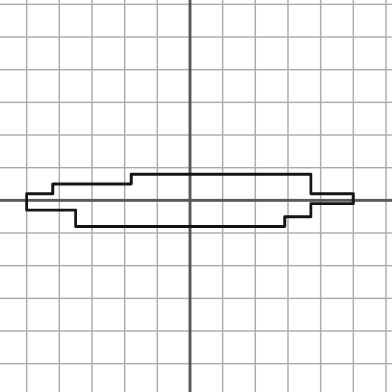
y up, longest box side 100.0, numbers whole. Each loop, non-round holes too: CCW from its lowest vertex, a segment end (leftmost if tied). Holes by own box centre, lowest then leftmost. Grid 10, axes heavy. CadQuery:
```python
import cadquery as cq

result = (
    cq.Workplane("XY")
    .moveTo(-35.0, -8.0)
    .lineTo(29.0, -8.0)
    .lineTo(29.0, -5.0)
    .lineTo(37.0, -5.0)
    .lineTo(37.0, -1.0)
    .lineTo(50.0, -1.0)
    .lineTo(50.0, 2.0)
    .lineTo(37.0, 2.0)
    .lineTo(37.0, 8.0)
    .lineTo(-18.0, 8.0)
    .lineTo(-18.0, 5.0)
    .lineTo(-42.0, 5.0)
    .lineTo(-42.0, 2.0)
    .lineTo(-50.0, 2.0)
    .lineTo(-50.0, -3.0)
    .lineTo(-35.0, -3.0)
    .close()
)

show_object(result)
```